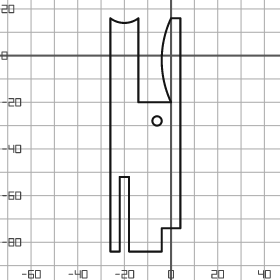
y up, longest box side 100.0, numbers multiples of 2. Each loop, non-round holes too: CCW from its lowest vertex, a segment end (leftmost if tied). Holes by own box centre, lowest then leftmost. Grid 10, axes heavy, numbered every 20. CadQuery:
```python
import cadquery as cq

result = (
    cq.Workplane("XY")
    .moveTo(-26.0, -84.0)
    .lineTo(-22.0, -84.0)
    .lineTo(-22.0, -52.0)
    .lineTo(-18.0, -52.0)
    .lineTo(-18.0, -84.0)
    .lineTo(-4.0, -84.0)
    .lineTo(-4.0, -74.0)
    .lineTo(4.0, -74.0)
    .lineTo(4.0, 16.0)
    .lineTo(0.0, 16.0)
    .threePointArc((-4.0, -2.0), (0.0, -20.0))
    .lineTo(-14.0, -20.0)
    .lineTo(-14.0, 16.0)
    .threePointArc((-20.0, 14.0), (-26.0, 16.0))
    .close()
    .moveTo(-6.0, -28.0)
    .circle(2.0)
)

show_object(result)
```